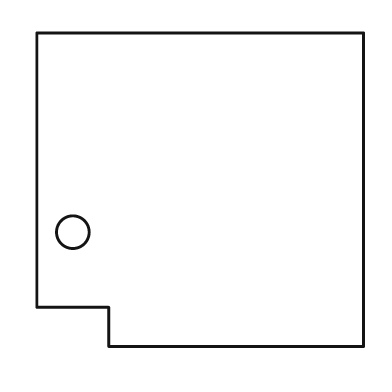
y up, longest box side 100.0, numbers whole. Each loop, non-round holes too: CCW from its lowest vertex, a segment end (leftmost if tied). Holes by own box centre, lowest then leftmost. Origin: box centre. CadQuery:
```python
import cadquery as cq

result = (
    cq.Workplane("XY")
    .moveTo(-28.0, -48.0)
    .lineTo(50.0, -48.0)
    .lineTo(50.0, 48.0)
    .lineTo(-50.0, 48.0)
    .lineTo(-50.0, -36.0)
    .lineTo(-28.0, -36.0)
    .close()
    .moveTo(-39.0, -13.0)
    .circle(5.0)
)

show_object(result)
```